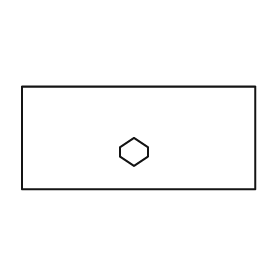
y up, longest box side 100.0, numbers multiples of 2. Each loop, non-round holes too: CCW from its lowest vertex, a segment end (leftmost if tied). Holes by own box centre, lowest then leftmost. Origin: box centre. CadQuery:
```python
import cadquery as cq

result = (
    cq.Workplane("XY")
    .moveTo(-50.0, -22.0)
    .lineTo(50.0, -22.0)
    .lineTo(50.0, 22.0)
    .lineTo(-50.0, 22.0)
    .close()
    .moveTo(-2.0, -12.0)
    .lineTo(4.0, -8.0)
    .lineTo(4.0, -4.0)
    .lineTo(-2.0, 0.0)
    .lineTo(-8.0, -4.0)
    .lineTo(-8.0, -8.0)
    .close()
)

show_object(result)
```